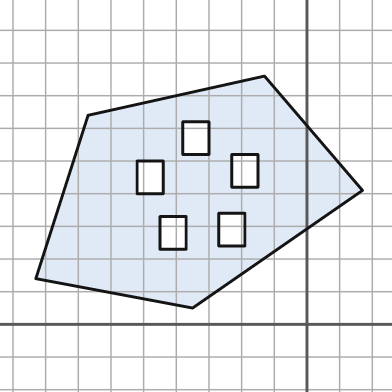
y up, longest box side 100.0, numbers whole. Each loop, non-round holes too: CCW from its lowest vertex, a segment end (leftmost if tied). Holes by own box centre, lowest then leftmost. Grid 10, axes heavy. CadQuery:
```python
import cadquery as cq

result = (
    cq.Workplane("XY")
    .moveTo(-35.0, 5.0)
    .lineTo(17.0, 41.0)
    .lineTo(-13.0, 76.0)
    .lineTo(-67.0, 64.0)
    .lineTo(-83.0, 14.0)
    .close()
    .moveTo(-45.0, 23.0)
    .lineTo(-37.0, 23.0)
    .lineTo(-37.0, 33.0)
    .lineTo(-45.0, 33.0)
    .close()
    .moveTo(-27.0, 24.0)
    .lineTo(-19.0, 24.0)
    .lineTo(-19.0, 34.0)
    .lineTo(-27.0, 34.0)
    .close()
    .moveTo(-52.0, 40.0)
    .lineTo(-44.0, 40.0)
    .lineTo(-44.0, 50.0)
    .lineTo(-52.0, 50.0)
    .close()
    .moveTo(-23.0, 42.0)
    .lineTo(-15.0, 42.0)
    .lineTo(-15.0, 52.0)
    .lineTo(-23.0, 52.0)
    .close()
    .moveTo(-38.0, 52.0)
    .lineTo(-30.0, 52.0)
    .lineTo(-30.0, 62.0)
    .lineTo(-38.0, 62.0)
    .close()
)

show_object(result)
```